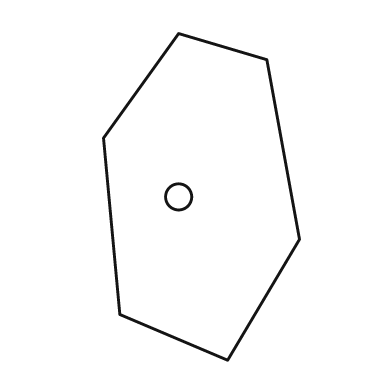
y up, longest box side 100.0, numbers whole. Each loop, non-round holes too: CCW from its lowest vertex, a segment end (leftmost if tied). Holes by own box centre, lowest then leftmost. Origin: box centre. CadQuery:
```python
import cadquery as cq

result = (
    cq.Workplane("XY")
    .moveTo(8.0, -50.0)
    .lineTo(30.0, -13.0)
    .lineTo(20.0, 42.0)
    .lineTo(-7.0, 50.0)
    .lineTo(-30.0, 18.0)
    .lineTo(-25.0, -36.0)
    .close()
    .moveTo(-7.0, 0.0)
    .circle(4.0)
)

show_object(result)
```